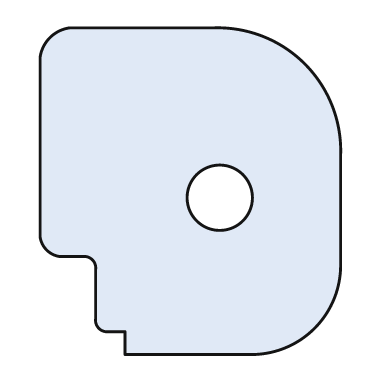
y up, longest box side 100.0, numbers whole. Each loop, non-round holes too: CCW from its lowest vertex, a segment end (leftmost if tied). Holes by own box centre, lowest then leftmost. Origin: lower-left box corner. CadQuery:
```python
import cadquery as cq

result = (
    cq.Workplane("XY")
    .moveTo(26.0, 0.0)
    .lineTo(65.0, 0.0)
    .threePointArc((84.0, 8.0), (92.0, 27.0))
    .lineTo(92.0, 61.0)
    .threePointArc((81.0, 89.0), (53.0, 100.0))
    .lineTo(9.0, 100.0)
    .threePointArc((3.0, 97.0), (0.0, 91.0))
    .lineTo(0.0, 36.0)
    .threePointArc((2.0, 32.0), (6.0, 30.0))
    .lineTo(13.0, 30.0)
    .threePointArc((16.0, 29.0), (17.0, 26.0))
    .lineTo(17.0, 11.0)
    .threePointArc((18.0, 8.0), (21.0, 7.0))
    .lineTo(26.0, 7.0)
    .close()
    .moveTo(55.0, 48.0)
    .circle(10.0)
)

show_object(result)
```